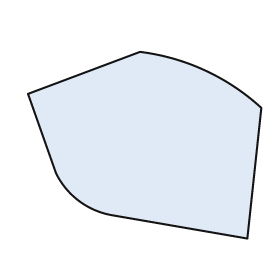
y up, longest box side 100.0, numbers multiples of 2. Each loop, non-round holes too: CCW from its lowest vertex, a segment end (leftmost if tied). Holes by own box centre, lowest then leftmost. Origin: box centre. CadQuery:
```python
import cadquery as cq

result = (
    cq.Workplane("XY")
    .moveTo(44.0, -40.0)
    .lineTo(50.0, 16.0)
    .threePointArc((26.0, 32.0), (-2.0, 40.0))
    .lineTo(-50.0, 22.0)
    .lineTo(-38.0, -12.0)
    .threePointArc((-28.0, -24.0), (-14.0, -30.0))
    .close()
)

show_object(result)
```